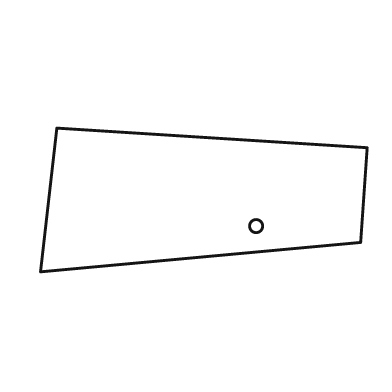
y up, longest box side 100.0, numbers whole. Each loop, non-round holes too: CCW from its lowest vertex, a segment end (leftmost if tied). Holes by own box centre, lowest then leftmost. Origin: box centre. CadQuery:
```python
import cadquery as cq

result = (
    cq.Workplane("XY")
    .moveTo(-50.0, -22.0)
    .lineTo(48.0, -13.0)
    .lineTo(50.0, 16.0)
    .lineTo(-45.0, 22.0)
    .close()
    .moveTo(16.0, -8.0)
    .circle(2.0)
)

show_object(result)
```